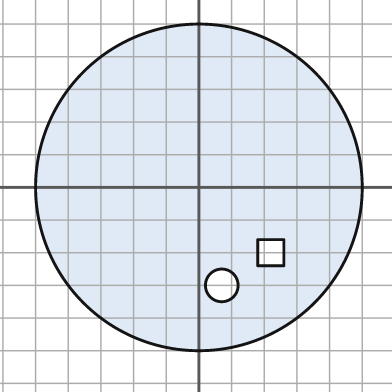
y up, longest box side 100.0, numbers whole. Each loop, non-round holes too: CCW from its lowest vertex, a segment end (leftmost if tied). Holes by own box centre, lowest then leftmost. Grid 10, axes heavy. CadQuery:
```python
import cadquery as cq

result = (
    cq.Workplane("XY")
    .moveTo(0.0, 0.0)
    .circle(50.0)
    .moveTo(7.0, -30.0)
    .circle(5.0)
    .moveTo(18.0, -24.0)
    .lineTo(26.0, -24.0)
    .lineTo(26.0, -16.0)
    .lineTo(18.0, -16.0)
    .close()
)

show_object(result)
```